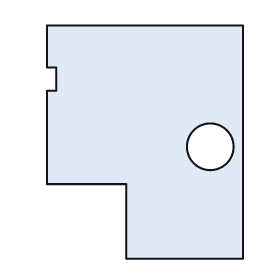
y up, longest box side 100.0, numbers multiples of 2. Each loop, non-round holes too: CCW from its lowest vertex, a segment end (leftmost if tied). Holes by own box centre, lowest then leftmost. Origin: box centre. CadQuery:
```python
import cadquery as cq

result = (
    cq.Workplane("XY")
    .moveTo(-8.0, -50.0)
    .lineTo(42.0, -50.0)
    .lineTo(42.0, 50.0)
    .lineTo(-42.0, 50.0)
    .lineTo(-42.0, 32.0)
    .lineTo(-38.0, 32.0)
    .lineTo(-38.0, 22.0)
    .lineTo(-42.0, 22.0)
    .lineTo(-42.0, -18.0)
    .lineTo(-8.0, -18.0)
    .close()
    .moveTo(28.0, -2.0)
    .circle(10.0)
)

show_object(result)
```